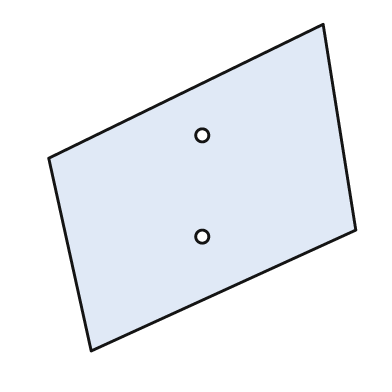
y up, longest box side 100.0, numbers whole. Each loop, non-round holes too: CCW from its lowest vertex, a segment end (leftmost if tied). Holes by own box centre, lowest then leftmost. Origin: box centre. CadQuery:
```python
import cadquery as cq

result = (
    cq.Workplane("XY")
    .moveTo(-34.0, -50.0)
    .lineTo(47.0, -13.0)
    .lineTo(37.0, 50.0)
    .lineTo(-47.0, 9.0)
    .close()
    .moveTo(0.0, -15.0)
    .circle(2.0)
    .moveTo(0.0, 16.0)
    .circle(2.0)
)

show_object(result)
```